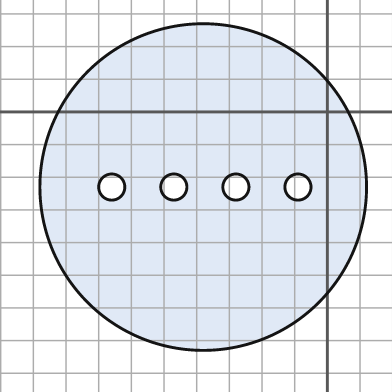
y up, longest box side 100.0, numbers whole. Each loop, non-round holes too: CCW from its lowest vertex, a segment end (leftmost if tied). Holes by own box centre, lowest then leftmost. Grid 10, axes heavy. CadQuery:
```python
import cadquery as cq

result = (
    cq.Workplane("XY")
    .moveTo(-38.0, -23.0)
    .circle(50.0)
    .moveTo(-66.0, -23.0)
    .circle(4.0)
    .moveTo(-47.0, -23.0)
    .circle(4.0)
    .moveTo(-28.0, -23.0)
    .circle(4.0)
    .moveTo(-9.0, -23.0)
    .circle(4.0)
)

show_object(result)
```